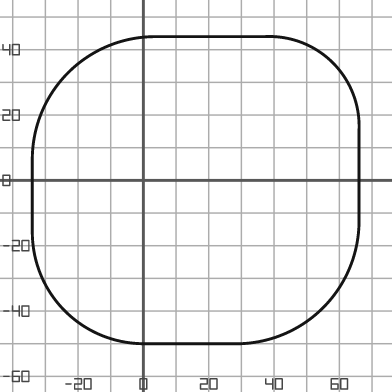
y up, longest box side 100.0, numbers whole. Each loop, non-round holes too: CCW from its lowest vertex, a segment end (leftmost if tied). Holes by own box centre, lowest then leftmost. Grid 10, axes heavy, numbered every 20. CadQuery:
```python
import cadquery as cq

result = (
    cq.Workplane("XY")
    .moveTo(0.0, -50.0)
    .lineTo(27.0, -50.0)
    .threePointArc((55.0, -39.0), (66.0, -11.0))
    .lineTo(66.0, 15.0)
    .threePointArc((58.0, 36.0), (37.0, 44.0))
    .lineTo(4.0, 44.0)
    .threePointArc((-23.0, 33.0), (-34.0, 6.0))
    .lineTo(-34.0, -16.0)
    .threePointArc((-24.0, -40.0), (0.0, -50.0))
    .close()
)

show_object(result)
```